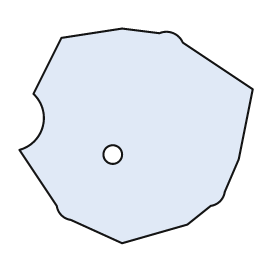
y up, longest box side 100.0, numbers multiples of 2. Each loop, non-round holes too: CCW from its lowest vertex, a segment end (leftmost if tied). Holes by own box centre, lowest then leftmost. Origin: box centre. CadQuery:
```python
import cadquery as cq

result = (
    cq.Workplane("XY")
    .moveTo(-6.0, -46.0)
    .lineTo(22.0, -38.0)
    .lineTo(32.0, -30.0)
    .threePointArc((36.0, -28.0), (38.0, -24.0))
    .lineTo(44.0, -10.0)
    .lineTo(50.0, 20.0)
    .lineTo(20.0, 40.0)
    .threePointArc((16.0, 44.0), (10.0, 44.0))
    .lineTo(-6.0, 46.0)
    .lineTo(-32.0, 42.0)
    .lineTo(-44.0, 18.0)
    .threePointArc((-40.0, 4.0), (-50.0, -6.0))
    .lineTo(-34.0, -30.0)
    .threePointArc((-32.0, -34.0), (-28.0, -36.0))
    .close()
    .moveTo(-10.0, -8.0)
    .circle(4.0)
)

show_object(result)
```